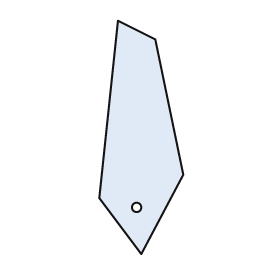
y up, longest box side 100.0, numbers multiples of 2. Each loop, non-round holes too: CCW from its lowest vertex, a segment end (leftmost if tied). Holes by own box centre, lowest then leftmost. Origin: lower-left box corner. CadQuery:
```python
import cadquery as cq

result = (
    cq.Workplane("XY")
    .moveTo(18.0, 0.0)
    .lineTo(36.0, 34.0)
    .lineTo(24.0, 92.0)
    .lineTo(8.0, 100.0)
    .lineTo(0.0, 24.0)
    .close()
    .moveTo(16.0, 20.0)
    .circle(2.0)
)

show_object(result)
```